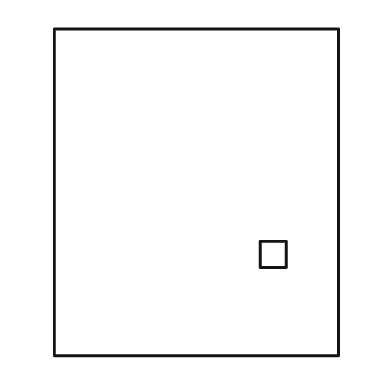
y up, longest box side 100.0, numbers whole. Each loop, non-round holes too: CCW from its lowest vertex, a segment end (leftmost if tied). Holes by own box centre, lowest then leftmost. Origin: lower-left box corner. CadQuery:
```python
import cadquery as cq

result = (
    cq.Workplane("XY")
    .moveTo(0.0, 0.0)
    .lineTo(87.0, 0.0)
    .lineTo(87.0, 100.0)
    .lineTo(0.0, 100.0)
    .close()
    .moveTo(63.0, 27.0)
    .lineTo(71.0, 27.0)
    .lineTo(71.0, 35.0)
    .lineTo(63.0, 35.0)
    .close()
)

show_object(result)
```